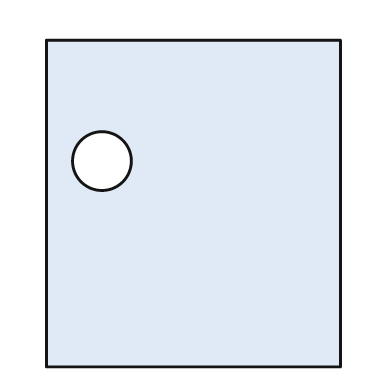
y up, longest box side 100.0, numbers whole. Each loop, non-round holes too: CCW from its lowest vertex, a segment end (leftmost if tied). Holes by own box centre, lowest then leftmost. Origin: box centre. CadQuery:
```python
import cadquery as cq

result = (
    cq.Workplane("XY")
    .moveTo(-45.0, -50.0)
    .lineTo(45.0, -50.0)
    .lineTo(45.0, 50.0)
    .lineTo(-45.0, 50.0)
    .close()
    .moveTo(-28.0, 13.0)
    .circle(9.0)
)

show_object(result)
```